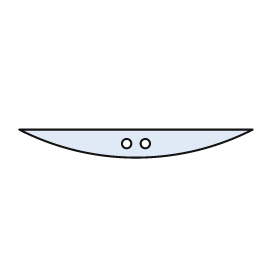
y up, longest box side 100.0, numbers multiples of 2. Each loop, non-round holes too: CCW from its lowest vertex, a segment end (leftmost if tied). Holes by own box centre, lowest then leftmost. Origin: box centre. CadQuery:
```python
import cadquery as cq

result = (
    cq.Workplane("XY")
    .moveTo(-50.0, 6.0)
    .threePointArc((0.0, -6.0), (50.0, 6.0))
    .close()
    .moveTo(-4.0, 0.0)
    .circle(2.0)
    .moveTo(4.0, 0.0)
    .circle(2.0)
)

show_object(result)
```